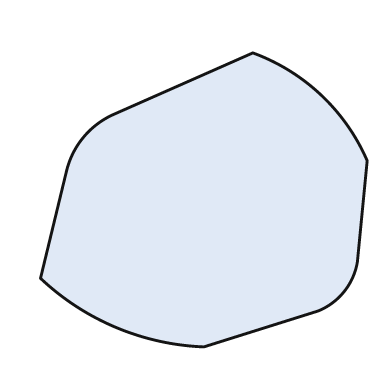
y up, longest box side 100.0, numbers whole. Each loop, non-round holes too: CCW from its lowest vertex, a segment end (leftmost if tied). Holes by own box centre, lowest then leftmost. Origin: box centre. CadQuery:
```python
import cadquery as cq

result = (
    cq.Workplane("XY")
    .moveTo(0.0, -45.0)
    .lineTo(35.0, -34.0)
    .threePointArc((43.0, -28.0), (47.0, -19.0))
    .lineTo(50.0, 12.0)
    .threePointArc((36.0, 32.0), (15.0, 45.0))
    .lineTo(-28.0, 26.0)
    .threePointArc((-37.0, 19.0), (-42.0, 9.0))
    .lineTo(-50.0, -24.0)
    .threePointArc((-27.0, -39.0), (0.0, -45.0))
    .close()
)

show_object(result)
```